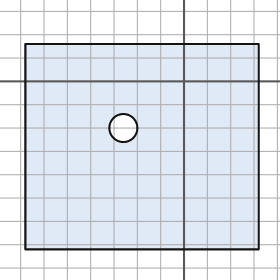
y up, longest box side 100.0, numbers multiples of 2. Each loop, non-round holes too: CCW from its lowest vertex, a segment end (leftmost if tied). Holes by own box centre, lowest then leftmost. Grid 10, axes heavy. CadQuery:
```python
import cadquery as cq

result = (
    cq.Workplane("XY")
    .moveTo(-68.0, -72.0)
    .lineTo(32.0, -72.0)
    .lineTo(32.0, 16.0)
    .lineTo(-68.0, 16.0)
    .close()
    .moveTo(-26.0, -20.0)
    .circle(6.0)
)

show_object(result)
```